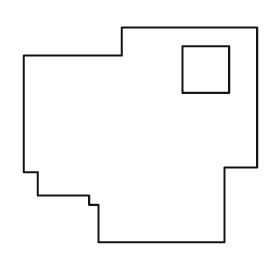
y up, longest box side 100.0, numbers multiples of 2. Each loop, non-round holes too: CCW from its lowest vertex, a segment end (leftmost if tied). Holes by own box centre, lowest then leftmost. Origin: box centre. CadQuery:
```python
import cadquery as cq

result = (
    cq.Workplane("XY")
    .moveTo(-18.0, -46.0)
    .lineTo(36.0, -46.0)
    .lineTo(36.0, -14.0)
    .lineTo(50.0, -14.0)
    .lineTo(50.0, 46.0)
    .lineTo(-8.0, 46.0)
    .lineTo(-8.0, 34.0)
    .lineTo(-50.0, 34.0)
    .lineTo(-50.0, -16.0)
    .lineTo(-44.0, -16.0)
    .lineTo(-44.0, -26.0)
    .lineTo(-22.0, -26.0)
    .lineTo(-22.0, -30.0)
    .lineTo(-18.0, -30.0)
    .close()
    .moveTo(18.0, 18.0)
    .lineTo(38.0, 18.0)
    .lineTo(38.0, 38.0)
    .lineTo(18.0, 38.0)
    .close()
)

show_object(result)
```